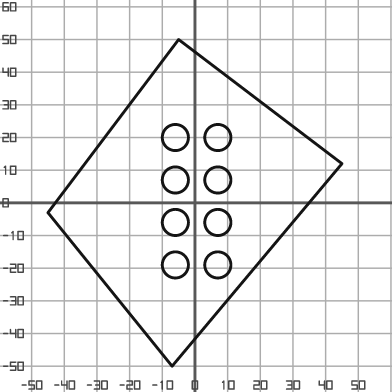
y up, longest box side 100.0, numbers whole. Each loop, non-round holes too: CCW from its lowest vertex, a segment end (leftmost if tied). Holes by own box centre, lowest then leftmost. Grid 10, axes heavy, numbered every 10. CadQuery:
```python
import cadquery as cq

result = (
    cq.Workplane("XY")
    .moveTo(-7.0, -50.0)
    .lineTo(45.0, 12.0)
    .lineTo(-5.0, 50.0)
    .lineTo(-45.0, -3.0)
    .close()
    .moveTo(-6.0, -19.0)
    .circle(4.0)
    .moveTo(7.0, -19.0)
    .circle(4.0)
    .moveTo(-6.0, -6.0)
    .circle(4.0)
    .moveTo(7.0, -6.0)
    .circle(4.0)
    .moveTo(-6.0, 7.0)
    .circle(4.0)
    .moveTo(7.0, 7.0)
    .circle(4.0)
    .moveTo(-6.0, 20.0)
    .circle(4.0)
    .moveTo(7.0, 20.0)
    .circle(4.0)
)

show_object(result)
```